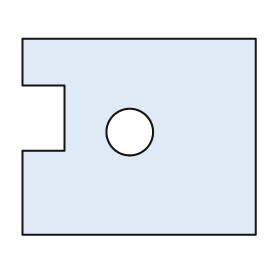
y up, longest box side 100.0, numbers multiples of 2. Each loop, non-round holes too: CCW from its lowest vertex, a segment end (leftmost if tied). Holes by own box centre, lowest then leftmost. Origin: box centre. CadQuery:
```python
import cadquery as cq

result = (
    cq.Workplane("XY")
    .moveTo(-50.0, -42.0)
    .lineTo(50.0, -42.0)
    .lineTo(50.0, 42.0)
    .lineTo(-50.0, 42.0)
    .lineTo(-50.0, 22.0)
    .lineTo(-32.0, 22.0)
    .lineTo(-32.0, -6.0)
    .lineTo(-50.0, -6.0)
    .close()
    .moveTo(-4.0, 2.0)
    .circle(10.0)
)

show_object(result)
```